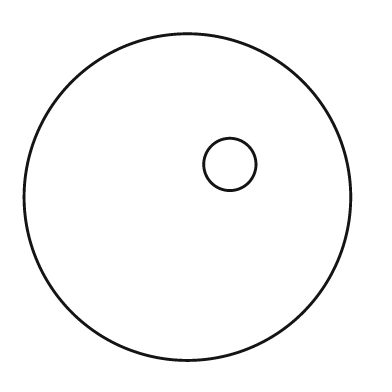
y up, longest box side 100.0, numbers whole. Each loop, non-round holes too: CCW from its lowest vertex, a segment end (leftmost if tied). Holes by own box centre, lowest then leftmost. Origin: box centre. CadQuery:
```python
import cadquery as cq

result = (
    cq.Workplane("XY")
    .moveTo(0.0, 0.0)
    .circle(50.0)
    .moveTo(13.0, 10.0)
    .circle(8.0)
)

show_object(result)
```